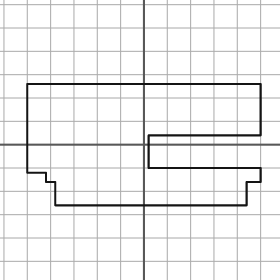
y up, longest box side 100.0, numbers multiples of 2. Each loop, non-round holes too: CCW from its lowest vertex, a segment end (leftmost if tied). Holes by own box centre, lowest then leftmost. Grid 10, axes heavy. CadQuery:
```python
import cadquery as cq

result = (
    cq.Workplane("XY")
    .moveTo(-38.0, -26.0)
    .lineTo(44.0, -26.0)
    .lineTo(44.0, -16.0)
    .lineTo(50.0, -16.0)
    .lineTo(50.0, -10.0)
    .lineTo(2.0, -10.0)
    .lineTo(2.0, 4.0)
    .lineTo(50.0, 4.0)
    .lineTo(50.0, 26.0)
    .lineTo(-50.0, 26.0)
    .lineTo(-50.0, -12.0)
    .lineTo(-42.0, -12.0)
    .lineTo(-42.0, -16.0)
    .lineTo(-38.0, -16.0)
    .close()
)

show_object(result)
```